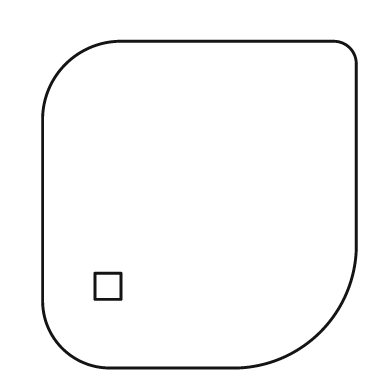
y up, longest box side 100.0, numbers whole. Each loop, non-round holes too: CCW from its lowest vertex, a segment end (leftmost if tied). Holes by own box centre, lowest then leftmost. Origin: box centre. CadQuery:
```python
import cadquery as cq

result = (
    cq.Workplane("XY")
    .moveTo(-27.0, -50.0)
    .lineTo(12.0, -50.0)
    .threePointArc((37.0, -39.0), (48.0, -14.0))
    .lineTo(48.0, 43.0)
    .threePointArc((46.0, 48.0), (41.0, 50.0))
    .lineTo(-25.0, 50.0)
    .threePointArc((-41.0, 43.0), (-48.0, 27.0))
    .lineTo(-48.0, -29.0)
    .threePointArc((-42.0, -44.0), (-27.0, -50.0))
    .close()
    .moveTo(-32.0, -29.0)
    .lineTo(-24.0, -29.0)
    .lineTo(-24.0, -21.0)
    .lineTo(-32.0, -21.0)
    .close()
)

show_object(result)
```